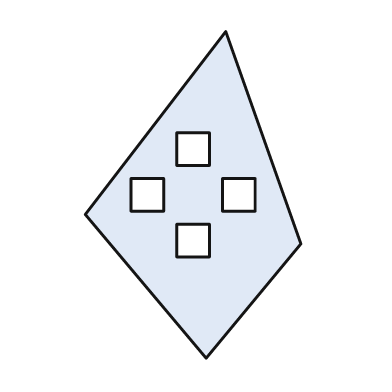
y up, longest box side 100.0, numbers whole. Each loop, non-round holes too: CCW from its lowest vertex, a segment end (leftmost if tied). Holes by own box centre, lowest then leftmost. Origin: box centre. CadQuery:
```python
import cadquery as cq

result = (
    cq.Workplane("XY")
    .moveTo(4.0, -50.0)
    .lineTo(33.0, -15.0)
    .lineTo(10.0, 50.0)
    .lineTo(-33.0, -6.0)
    .close()
    .moveTo(-5.0, -19.0)
    .lineTo(5.0, -19.0)
    .lineTo(5.0, -9.0)
    .lineTo(-5.0, -9.0)
    .close()
    .moveTo(-19.0, -5.0)
    .lineTo(-9.0, -5.0)
    .lineTo(-9.0, 5.0)
    .lineTo(-19.0, 5.0)
    .close()
    .moveTo(9.0, -5.0)
    .lineTo(19.0, -5.0)
    .lineTo(19.0, 5.0)
    .lineTo(9.0, 5.0)
    .close()
    .moveTo(-5.0, 9.0)
    .lineTo(5.0, 9.0)
    .lineTo(5.0, 19.0)
    .lineTo(-5.0, 19.0)
    .close()
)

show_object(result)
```